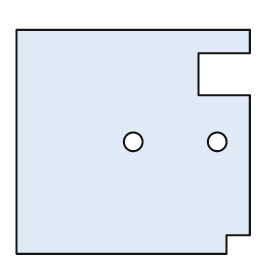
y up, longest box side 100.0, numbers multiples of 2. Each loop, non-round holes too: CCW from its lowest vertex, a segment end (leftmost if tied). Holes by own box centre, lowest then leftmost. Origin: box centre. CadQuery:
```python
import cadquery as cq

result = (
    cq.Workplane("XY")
    .moveTo(-50.0, -48.0)
    .lineTo(40.0, -48.0)
    .lineTo(40.0, -40.0)
    .lineTo(50.0, -40.0)
    .lineTo(50.0, 20.0)
    .lineTo(28.0, 20.0)
    .lineTo(28.0, 38.0)
    .lineTo(50.0, 38.0)
    .lineTo(50.0, 48.0)
    .lineTo(-50.0, 48.0)
    .close()
    .moveTo(0.0, 0.0)
    .circle(4.0)
    .moveTo(36.0, 0.0)
    .circle(4.0)
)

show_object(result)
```